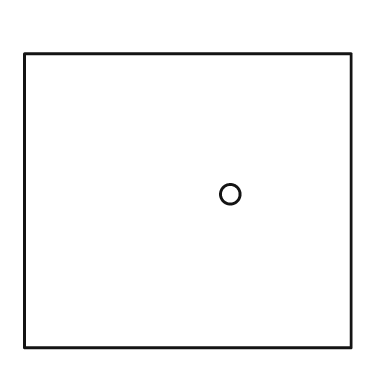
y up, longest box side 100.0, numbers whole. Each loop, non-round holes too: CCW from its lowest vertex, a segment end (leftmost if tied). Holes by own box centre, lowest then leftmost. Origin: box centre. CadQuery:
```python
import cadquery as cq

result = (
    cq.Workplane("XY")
    .moveTo(-50.0, -45.0)
    .lineTo(50.0, -45.0)
    .lineTo(50.0, 45.0)
    .lineTo(-50.0, 45.0)
    .close()
    .moveTo(13.0, 2.0)
    .circle(3.0)
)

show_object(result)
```